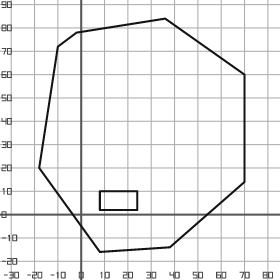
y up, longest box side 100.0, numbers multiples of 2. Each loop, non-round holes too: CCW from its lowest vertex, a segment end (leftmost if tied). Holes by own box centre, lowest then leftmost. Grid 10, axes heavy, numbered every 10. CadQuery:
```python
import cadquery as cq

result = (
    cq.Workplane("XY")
    .moveTo(8.0, -16.0)
    .lineTo(38.0, -14.0)
    .lineTo(70.0, 14.0)
    .lineTo(70.0, 60.0)
    .lineTo(36.0, 84.0)
    .lineTo(-2.0, 78.0)
    .lineTo(-10.0, 72.0)
    .lineTo(-18.0, 20.0)
    .close()
    .moveTo(8.0, 2.0)
    .lineTo(24.0, 2.0)
    .lineTo(24.0, 10.0)
    .lineTo(8.0, 10.0)
    .close()
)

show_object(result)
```